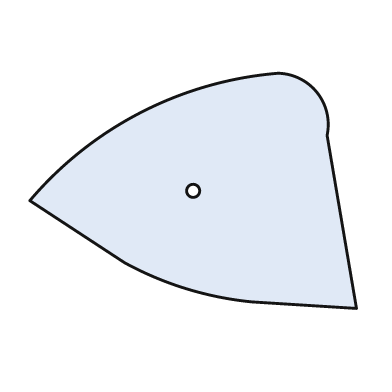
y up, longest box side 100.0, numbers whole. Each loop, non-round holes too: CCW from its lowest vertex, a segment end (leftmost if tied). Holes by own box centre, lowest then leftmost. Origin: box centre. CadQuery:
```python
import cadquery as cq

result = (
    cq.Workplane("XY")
    .moveTo(50.0, -36.0)
    .lineTo(41.0, 17.0)
    .threePointArc((38.0, 30.0), (26.0, 36.0))
    .threePointArc((-16.0, 24.0), (-50.0, -3.0))
    .lineTo(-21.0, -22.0)
    .threePointArc((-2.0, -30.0), (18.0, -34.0))
    .close()
    .moveTo(0.0, 0.0)
    .circle(2.0)
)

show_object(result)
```